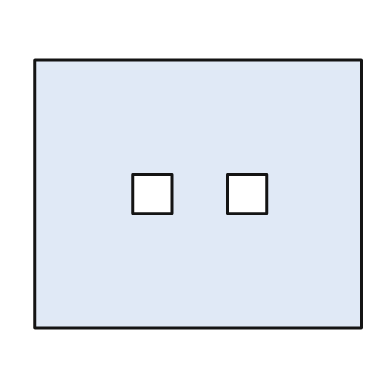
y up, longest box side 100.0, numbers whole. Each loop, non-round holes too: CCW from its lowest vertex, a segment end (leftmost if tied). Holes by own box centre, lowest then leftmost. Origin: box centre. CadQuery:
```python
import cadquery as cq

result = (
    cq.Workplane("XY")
    .moveTo(-50.0, -41.0)
    .lineTo(50.0, -41.0)
    .lineTo(50.0, 41.0)
    .lineTo(-50.0, 41.0)
    .close()
    .moveTo(-20.0, -6.0)
    .lineTo(-8.0, -6.0)
    .lineTo(-8.0, 6.0)
    .lineTo(-20.0, 6.0)
    .close()
    .moveTo(9.0, -6.0)
    .lineTo(21.0, -6.0)
    .lineTo(21.0, 6.0)
    .lineTo(9.0, 6.0)
    .close()
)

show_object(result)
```